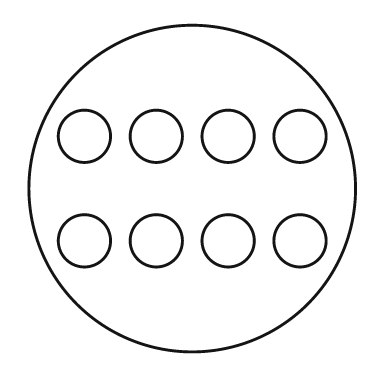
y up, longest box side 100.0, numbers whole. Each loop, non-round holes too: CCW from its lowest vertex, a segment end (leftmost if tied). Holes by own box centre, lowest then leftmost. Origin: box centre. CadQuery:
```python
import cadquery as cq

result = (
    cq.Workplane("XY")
    .moveTo(0.0, 0.0)
    .circle(50.0)
    .moveTo(-33.0, -16.0)
    .circle(8.0)
    .moveTo(-11.0, -16.0)
    .circle(8.0)
    .moveTo(11.0, -16.0)
    .circle(8.0)
    .moveTo(33.0, -16.0)
    .circle(8.0)
    .moveTo(-33.0, 16.0)
    .circle(8.0)
    .moveTo(-11.0, 16.0)
    .circle(8.0)
    .moveTo(11.0, 16.0)
    .circle(8.0)
    .moveTo(33.0, 16.0)
    .circle(8.0)
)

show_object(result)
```